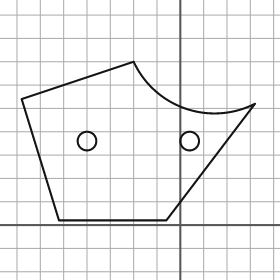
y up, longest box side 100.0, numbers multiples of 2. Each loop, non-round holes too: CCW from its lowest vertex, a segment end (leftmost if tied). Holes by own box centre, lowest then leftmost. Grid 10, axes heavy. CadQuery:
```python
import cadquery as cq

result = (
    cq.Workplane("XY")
    .moveTo(-52.0, 2.0)
    .lineTo(-6.0, 2.0)
    .lineTo(32.0, 52.0)
    .threePointArc((2.0, 50.0), (-20.0, 70.0))
    .lineTo(-68.0, 54.0)
    .close()
    .moveTo(-40.0, 36.0)
    .circle(4.0)
    .moveTo(4.0, 36.0)
    .circle(4.0)
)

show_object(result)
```